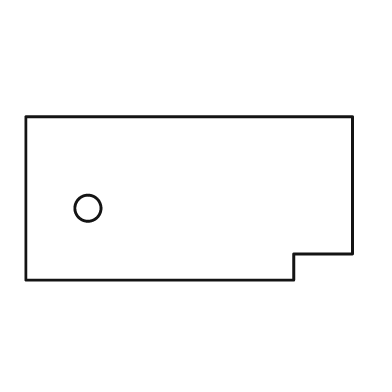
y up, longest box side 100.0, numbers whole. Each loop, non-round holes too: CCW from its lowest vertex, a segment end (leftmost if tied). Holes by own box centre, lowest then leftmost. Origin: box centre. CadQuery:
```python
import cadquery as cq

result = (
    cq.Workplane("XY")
    .moveTo(-50.0, -25.0)
    .lineTo(32.0, -25.0)
    .lineTo(32.0, -17.0)
    .lineTo(50.0, -17.0)
    .lineTo(50.0, 25.0)
    .lineTo(-50.0, 25.0)
    .close()
    .moveTo(-31.0, -3.0)
    .circle(4.0)
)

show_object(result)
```